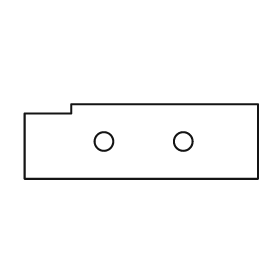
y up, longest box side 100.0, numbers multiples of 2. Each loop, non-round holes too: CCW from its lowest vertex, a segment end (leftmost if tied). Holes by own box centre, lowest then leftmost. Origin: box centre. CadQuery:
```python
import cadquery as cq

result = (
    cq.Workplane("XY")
    .moveTo(-50.0, -16.0)
    .lineTo(50.0, -16.0)
    .lineTo(50.0, 16.0)
    .lineTo(-30.0, 16.0)
    .lineTo(-30.0, 12.0)
    .lineTo(-50.0, 12.0)
    .close()
    .moveTo(-16.0, 0.0)
    .circle(4.0)
    .moveTo(18.0, 0.0)
    .circle(4.0)
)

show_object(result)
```